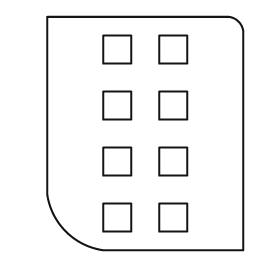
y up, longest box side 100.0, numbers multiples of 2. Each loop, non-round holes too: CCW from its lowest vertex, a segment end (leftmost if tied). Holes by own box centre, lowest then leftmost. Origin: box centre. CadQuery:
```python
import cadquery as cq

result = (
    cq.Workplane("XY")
    .moveTo(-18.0, -50.0)
    .lineTo(42.0, -50.0)
    .lineTo(42.0, 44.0)
    .threePointArc((40.0, 48.0), (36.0, 50.0))
    .lineTo(-42.0, 50.0)
    .lineTo(-42.0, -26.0)
    .threePointArc((-34.0, -42.0), (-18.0, -50.0))
    .close()
    .moveTo(-18.0, -42.0)
    .lineTo(-6.0, -42.0)
    .lineTo(-6.0, -30.0)
    .lineTo(-18.0, -30.0)
    .close()
    .moveTo(6.0, -42.0)
    .lineTo(18.0, -42.0)
    .lineTo(18.0, -30.0)
    .lineTo(6.0, -30.0)
    .close()
    .moveTo(-18.0, -18.0)
    .lineTo(-6.0, -18.0)
    .lineTo(-6.0, -6.0)
    .lineTo(-18.0, -6.0)
    .close()
    .moveTo(6.0, -18.0)
    .lineTo(18.0, -18.0)
    .lineTo(18.0, -6.0)
    .lineTo(6.0, -6.0)
    .close()
    .moveTo(-18.0, 6.0)
    .lineTo(-6.0, 6.0)
    .lineTo(-6.0, 18.0)
    .lineTo(-18.0, 18.0)
    .close()
    .moveTo(6.0, 6.0)
    .lineTo(18.0, 6.0)
    .lineTo(18.0, 18.0)
    .lineTo(6.0, 18.0)
    .close()
    .moveTo(-18.0, 30.0)
    .lineTo(-6.0, 30.0)
    .lineTo(-6.0, 42.0)
    .lineTo(-18.0, 42.0)
    .close()
    .moveTo(6.0, 30.0)
    .lineTo(18.0, 30.0)
    .lineTo(18.0, 42.0)
    .lineTo(6.0, 42.0)
    .close()
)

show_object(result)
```